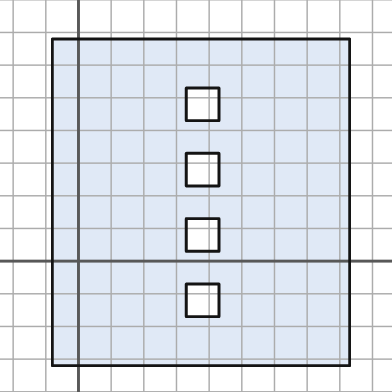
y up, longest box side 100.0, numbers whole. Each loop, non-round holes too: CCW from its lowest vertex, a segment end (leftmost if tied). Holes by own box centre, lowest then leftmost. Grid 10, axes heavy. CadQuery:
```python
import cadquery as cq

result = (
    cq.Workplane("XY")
    .moveTo(-8.0, -32.0)
    .lineTo(83.0, -32.0)
    .lineTo(83.0, 68.0)
    .lineTo(-8.0, 68.0)
    .close()
    .moveTo(33.0, -17.0)
    .lineTo(43.0, -17.0)
    .lineTo(43.0, -7.0)
    .lineTo(33.0, -7.0)
    .close()
    .moveTo(33.0, 3.0)
    .lineTo(43.0, 3.0)
    .lineTo(43.0, 13.0)
    .lineTo(33.0, 13.0)
    .close()
    .moveTo(33.0, 23.0)
    .lineTo(43.0, 23.0)
    .lineTo(43.0, 33.0)
    .lineTo(33.0, 33.0)
    .close()
    .moveTo(33.0, 43.0)
    .lineTo(43.0, 43.0)
    .lineTo(43.0, 53.0)
    .lineTo(33.0, 53.0)
    .close()
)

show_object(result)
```